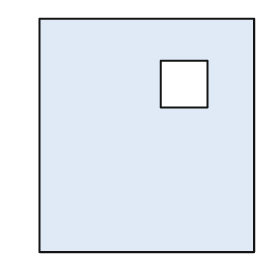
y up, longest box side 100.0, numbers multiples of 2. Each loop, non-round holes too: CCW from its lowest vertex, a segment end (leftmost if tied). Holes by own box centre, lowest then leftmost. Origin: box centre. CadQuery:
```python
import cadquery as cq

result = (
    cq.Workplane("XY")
    .moveTo(-46.0, -50.0)
    .lineTo(46.0, -50.0)
    .lineTo(46.0, 50.0)
    .lineTo(-46.0, 50.0)
    .close()
    .moveTo(6.0, 12.0)
    .lineTo(26.0, 12.0)
    .lineTo(26.0, 32.0)
    .lineTo(6.0, 32.0)
    .close()
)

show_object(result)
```